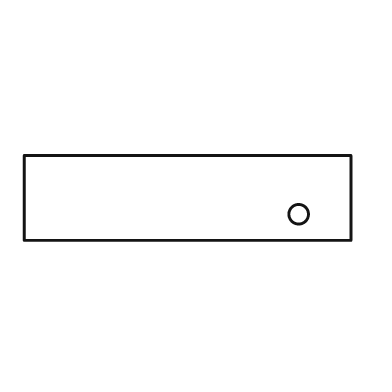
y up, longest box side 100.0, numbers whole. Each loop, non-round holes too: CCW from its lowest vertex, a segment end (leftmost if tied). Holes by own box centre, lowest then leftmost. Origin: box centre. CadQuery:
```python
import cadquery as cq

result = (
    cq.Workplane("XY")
    .moveTo(-50.0, -13.0)
    .lineTo(50.0, -13.0)
    .lineTo(50.0, 13.0)
    .lineTo(-50.0, 13.0)
    .close()
    .moveTo(34.0, -5.0)
    .circle(3.0)
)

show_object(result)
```